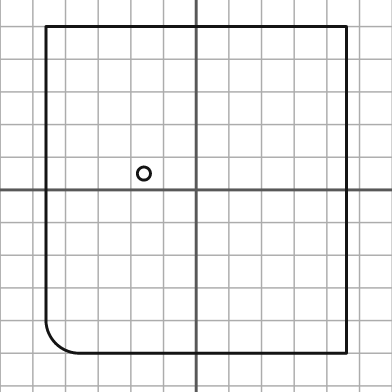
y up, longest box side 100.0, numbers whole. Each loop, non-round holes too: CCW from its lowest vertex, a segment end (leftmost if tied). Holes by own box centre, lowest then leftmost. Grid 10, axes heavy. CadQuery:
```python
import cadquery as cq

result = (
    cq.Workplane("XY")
    .moveTo(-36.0, -50.0)
    .lineTo(46.0, -50.0)
    .lineTo(46.0, 50.0)
    .lineTo(-46.0, 50.0)
    .lineTo(-46.0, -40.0)
    .threePointArc((-43.0, -47.0), (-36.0, -50.0))
    .close()
    .moveTo(-16.0, 5.0)
    .circle(2.0)
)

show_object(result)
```